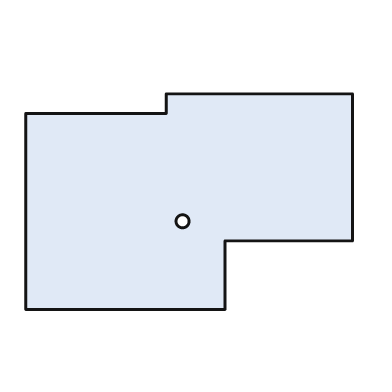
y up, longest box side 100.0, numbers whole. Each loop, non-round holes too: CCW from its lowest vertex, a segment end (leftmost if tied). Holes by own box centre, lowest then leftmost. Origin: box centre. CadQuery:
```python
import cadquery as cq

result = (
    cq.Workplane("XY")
    .moveTo(-50.0, -33.0)
    .lineTo(11.0, -33.0)
    .lineTo(11.0, -12.0)
    .lineTo(50.0, -12.0)
    .lineTo(50.0, 33.0)
    .lineTo(-7.0, 33.0)
    .lineTo(-7.0, 27.0)
    .lineTo(-50.0, 27.0)
    .close()
    .moveTo(-2.0, -6.0)
    .circle(2.0)
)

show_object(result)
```